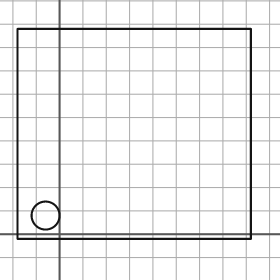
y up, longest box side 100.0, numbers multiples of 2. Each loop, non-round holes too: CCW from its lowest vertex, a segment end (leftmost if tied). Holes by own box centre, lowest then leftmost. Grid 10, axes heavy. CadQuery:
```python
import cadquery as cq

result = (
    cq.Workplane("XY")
    .moveTo(-18.0, -2.0)
    .lineTo(82.0, -2.0)
    .lineTo(82.0, 88.0)
    .lineTo(-18.0, 88.0)
    .close()
    .moveTo(-6.0, 8.0)
    .circle(6.0)
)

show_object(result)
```